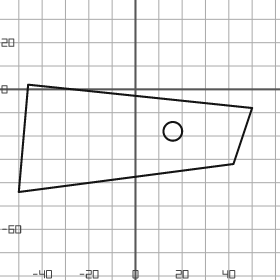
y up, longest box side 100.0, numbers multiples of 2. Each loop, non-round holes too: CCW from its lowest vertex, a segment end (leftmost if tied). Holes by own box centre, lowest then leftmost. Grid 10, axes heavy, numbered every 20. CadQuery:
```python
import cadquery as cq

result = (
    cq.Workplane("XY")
    .moveTo(-50.0, -44.0)
    .lineTo(42.0, -32.0)
    .lineTo(50.0, -8.0)
    .lineTo(-46.0, 2.0)
    .close()
    .moveTo(16.0, -18.0)
    .circle(4.0)
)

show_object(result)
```